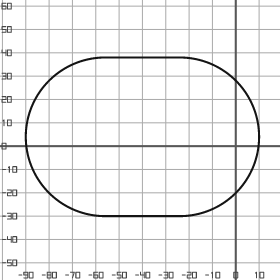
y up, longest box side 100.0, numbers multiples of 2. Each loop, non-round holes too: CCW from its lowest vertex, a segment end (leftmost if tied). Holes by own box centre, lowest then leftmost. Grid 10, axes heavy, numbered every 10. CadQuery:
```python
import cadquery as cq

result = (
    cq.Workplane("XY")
    .moveTo(-56.0, -30.0)
    .lineTo(-24.0, -30.0)
    .threePointArc((10.0, 4.0), (-24.0, 38.0))
    .lineTo(-56.0, 38.0)
    .threePointArc((-90.0, 4.0), (-56.0, -30.0))
    .close()
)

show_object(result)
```